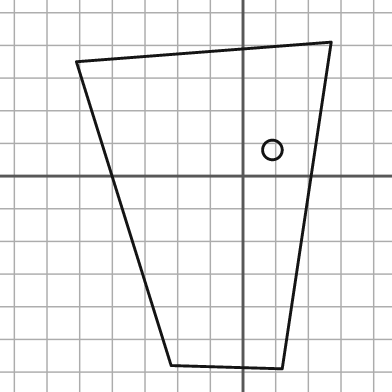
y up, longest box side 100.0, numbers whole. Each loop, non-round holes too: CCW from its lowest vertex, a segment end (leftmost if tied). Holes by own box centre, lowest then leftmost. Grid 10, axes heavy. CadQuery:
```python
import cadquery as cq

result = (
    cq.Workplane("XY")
    .moveTo(12.0, -59.0)
    .lineTo(27.0, 41.0)
    .lineTo(-51.0, 35.0)
    .lineTo(-22.0, -58.0)
    .close()
    .moveTo(9.0, 8.0)
    .circle(3.0)
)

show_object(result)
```